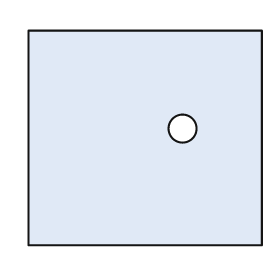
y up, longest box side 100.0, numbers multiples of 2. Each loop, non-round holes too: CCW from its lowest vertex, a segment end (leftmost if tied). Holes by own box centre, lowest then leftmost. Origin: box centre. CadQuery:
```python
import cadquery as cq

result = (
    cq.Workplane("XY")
    .moveTo(-50.0, -46.0)
    .lineTo(50.0, -46.0)
    .lineTo(50.0, 46.0)
    .lineTo(-50.0, 46.0)
    .close()
    .moveTo(16.0, 4.0)
    .circle(6.0)
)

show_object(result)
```